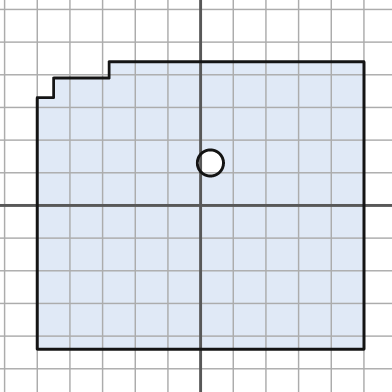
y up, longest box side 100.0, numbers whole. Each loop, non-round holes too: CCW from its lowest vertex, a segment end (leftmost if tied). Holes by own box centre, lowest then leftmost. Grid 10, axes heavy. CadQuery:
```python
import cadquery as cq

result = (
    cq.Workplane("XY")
    .moveTo(-50.0, -44.0)
    .lineTo(50.0, -44.0)
    .lineTo(50.0, 44.0)
    .lineTo(-28.0, 44.0)
    .lineTo(-28.0, 39.0)
    .lineTo(-45.0, 39.0)
    .lineTo(-45.0, 33.0)
    .lineTo(-50.0, 33.0)
    .close()
    .moveTo(3.0, 13.0)
    .circle(4.0)
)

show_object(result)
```